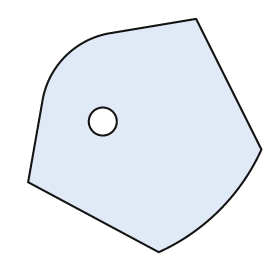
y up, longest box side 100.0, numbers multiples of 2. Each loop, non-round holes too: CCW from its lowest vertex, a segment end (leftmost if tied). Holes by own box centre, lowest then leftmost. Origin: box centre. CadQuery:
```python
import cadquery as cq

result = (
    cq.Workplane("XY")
    .moveTo(6.0, -50.0)
    .threePointArc((32.0, -32.0), (50.0, -6.0))
    .lineTo(22.0, 50.0)
    .lineTo(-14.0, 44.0)
    .threePointArc((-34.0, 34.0), (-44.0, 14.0))
    .lineTo(-50.0, -20.0)
    .close()
    .moveTo(-18.0, 6.0)
    .circle(6.0)
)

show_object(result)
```